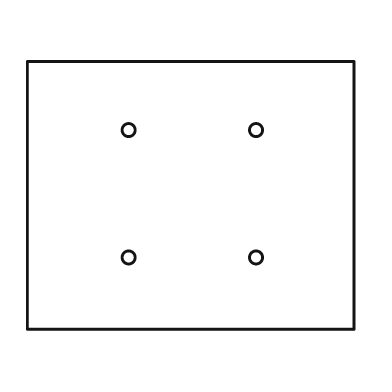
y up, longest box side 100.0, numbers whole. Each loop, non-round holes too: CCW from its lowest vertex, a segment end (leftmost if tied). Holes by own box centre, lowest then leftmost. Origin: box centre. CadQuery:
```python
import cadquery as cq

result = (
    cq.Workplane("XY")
    .moveTo(-50.0, -41.0)
    .lineTo(50.0, -41.0)
    .lineTo(50.0, 41.0)
    .lineTo(-50.0, 41.0)
    .close()
    .moveTo(-19.0, -19.0)
    .circle(2.0)
    .moveTo(20.0, -19.0)
    .circle(2.0)
    .moveTo(-19.0, 20.0)
    .circle(2.0)
    .moveTo(20.0, 20.0)
    .circle(2.0)
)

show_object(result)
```